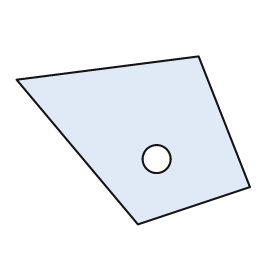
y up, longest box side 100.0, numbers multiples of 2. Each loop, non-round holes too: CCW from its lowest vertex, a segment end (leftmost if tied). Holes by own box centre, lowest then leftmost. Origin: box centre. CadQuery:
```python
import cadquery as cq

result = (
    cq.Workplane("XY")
    .moveTo(2.0, -36.0)
    .lineTo(50.0, -20.0)
    .lineTo(28.0, 36.0)
    .lineTo(-50.0, 26.0)
    .close()
    .moveTo(10.0, -8.0)
    .circle(6.0)
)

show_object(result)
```